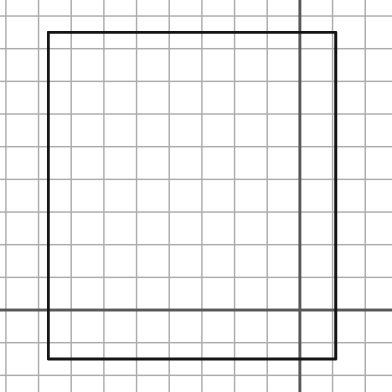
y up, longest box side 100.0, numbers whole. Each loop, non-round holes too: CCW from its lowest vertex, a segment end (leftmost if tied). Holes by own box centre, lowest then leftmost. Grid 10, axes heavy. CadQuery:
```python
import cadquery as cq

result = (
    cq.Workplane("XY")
    .moveTo(-77.0, -15.0)
    .lineTo(11.0, -15.0)
    .lineTo(11.0, 85.0)
    .lineTo(-77.0, 85.0)
    .close()
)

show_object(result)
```